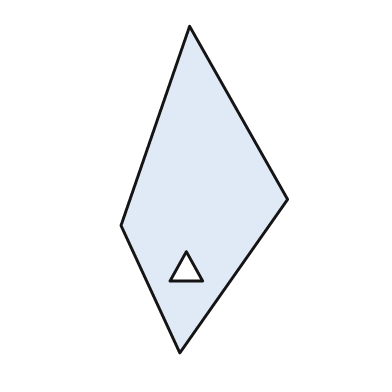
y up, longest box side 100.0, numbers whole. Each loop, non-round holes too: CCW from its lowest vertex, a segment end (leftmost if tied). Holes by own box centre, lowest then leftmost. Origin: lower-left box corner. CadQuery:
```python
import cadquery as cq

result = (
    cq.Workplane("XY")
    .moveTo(18.0, 0.0)
    .lineTo(51.0, 47.0)
    .lineTo(21.0, 100.0)
    .lineTo(0.0, 39.0)
    .close()
    .moveTo(15.0, 22.0)
    .lineTo(25.0, 22.0)
    .lineTo(20.0, 31.0)
    .close()
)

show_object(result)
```